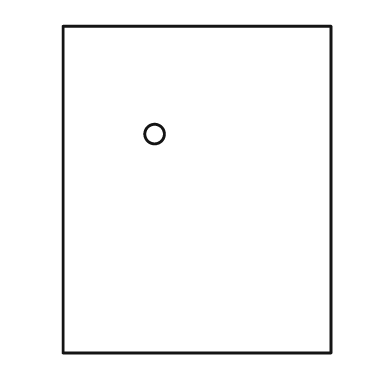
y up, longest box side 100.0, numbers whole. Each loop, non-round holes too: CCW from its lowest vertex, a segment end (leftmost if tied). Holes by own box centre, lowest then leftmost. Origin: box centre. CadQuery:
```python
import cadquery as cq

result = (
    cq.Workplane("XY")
    .moveTo(-41.0, -50.0)
    .lineTo(41.0, -50.0)
    .lineTo(41.0, 50.0)
    .lineTo(-41.0, 50.0)
    .close()
    .moveTo(-13.0, 17.0)
    .circle(3.0)
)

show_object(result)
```